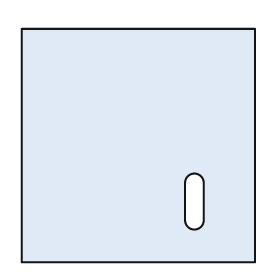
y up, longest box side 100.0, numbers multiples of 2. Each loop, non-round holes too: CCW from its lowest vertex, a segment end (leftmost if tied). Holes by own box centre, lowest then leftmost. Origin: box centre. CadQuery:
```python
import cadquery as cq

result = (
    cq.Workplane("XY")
    .moveTo(-50.0, -50.0)
    .lineTo(50.0, -50.0)
    .lineTo(50.0, 50.0)
    .lineTo(-50.0, 50.0)
    .close()
    .moveTo(20.0, -32.0)
    .threePointArc((24.0, -36.0), (28.0, -32.0))
    .lineTo(28.0, -16.0)
    .threePointArc((24.0, -12.0), (20.0, -16.0))
    .close()
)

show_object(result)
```